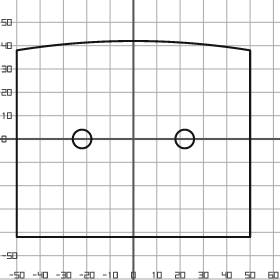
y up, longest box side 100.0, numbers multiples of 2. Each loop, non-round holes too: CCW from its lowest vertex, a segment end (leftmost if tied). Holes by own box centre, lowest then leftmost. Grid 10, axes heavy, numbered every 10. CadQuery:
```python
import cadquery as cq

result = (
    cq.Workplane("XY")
    .moveTo(-50.0, -42.0)
    .lineTo(50.0, -42.0)
    .lineTo(50.0, 38.0)
    .threePointArc((0.0, 42.0), (-50.0, 38.0))
    .close()
    .moveTo(-22.0, 0.0)
    .circle(4.0)
    .moveTo(22.0, 0.0)
    .circle(4.0)
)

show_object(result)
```